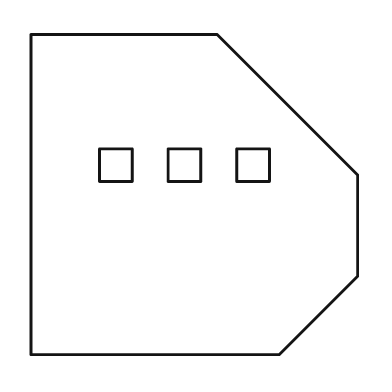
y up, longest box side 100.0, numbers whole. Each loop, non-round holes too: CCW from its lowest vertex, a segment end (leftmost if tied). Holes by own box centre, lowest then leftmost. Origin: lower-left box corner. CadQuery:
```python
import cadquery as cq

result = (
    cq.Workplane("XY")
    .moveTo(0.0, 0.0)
    .lineTo(76.0, 0.0)
    .lineTo(100.0, 24.0)
    .lineTo(100.0, 55.0)
    .lineTo(57.0, 98.0)
    .lineTo(0.0, 98.0)
    .close()
    .moveTo(21.0, 53.0)
    .lineTo(31.0, 53.0)
    .lineTo(31.0, 63.0)
    .lineTo(21.0, 63.0)
    .close()
    .moveTo(42.0, 53.0)
    .lineTo(52.0, 53.0)
    .lineTo(52.0, 63.0)
    .lineTo(42.0, 63.0)
    .close()
    .moveTo(63.0, 53.0)
    .lineTo(73.0, 53.0)
    .lineTo(73.0, 63.0)
    .lineTo(63.0, 63.0)
    .close()
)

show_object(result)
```